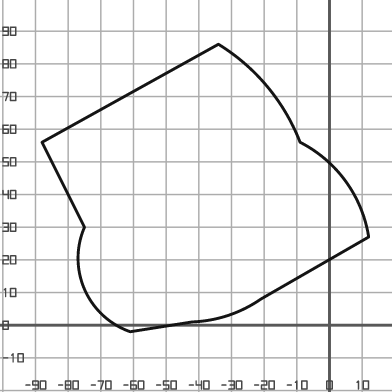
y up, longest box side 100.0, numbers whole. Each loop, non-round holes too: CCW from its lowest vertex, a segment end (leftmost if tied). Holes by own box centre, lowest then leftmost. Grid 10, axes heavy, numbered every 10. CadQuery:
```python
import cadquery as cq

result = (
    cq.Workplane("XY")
    .moveTo(-61.0, -2.0)
    .lineTo(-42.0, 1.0)
    .threePointArc((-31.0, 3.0), (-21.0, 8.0))
    .lineTo(12.0, 27.0)
    .threePointArc((5.0, 44.0), (-9.0, 56.0))
    .threePointArc((-19.0, 73.0), (-34.0, 86.0))
    .lineTo(-88.0, 56.0)
    .lineTo(-75.0, 30.0)
    .threePointArc((-75.0, 11.0), (-61.0, -2.0))
    .close()
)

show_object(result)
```